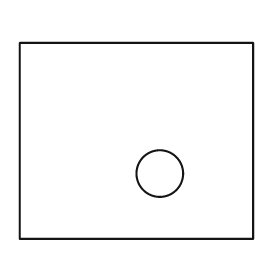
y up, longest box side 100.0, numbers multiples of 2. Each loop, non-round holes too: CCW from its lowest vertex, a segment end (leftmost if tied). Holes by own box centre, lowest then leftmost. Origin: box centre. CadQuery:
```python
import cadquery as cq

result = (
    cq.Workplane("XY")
    .moveTo(-50.0, -42.0)
    .lineTo(50.0, -42.0)
    .lineTo(50.0, 42.0)
    .lineTo(-50.0, 42.0)
    .close()
    .moveTo(10.0, -14.0)
    .circle(10.0)
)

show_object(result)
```